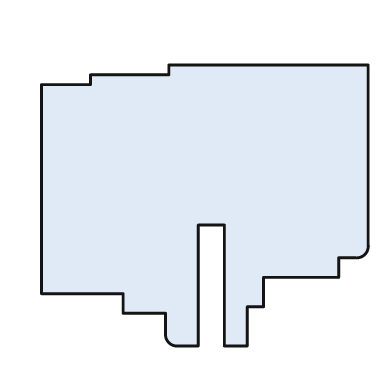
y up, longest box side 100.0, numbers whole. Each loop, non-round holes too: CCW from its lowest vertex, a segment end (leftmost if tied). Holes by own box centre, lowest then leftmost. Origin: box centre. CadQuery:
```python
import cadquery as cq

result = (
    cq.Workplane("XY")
    .moveTo(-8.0, -43.0)
    .lineTo(-2.0, -43.0)
    .lineTo(-2.0, -6.0)
    .lineTo(6.0, -6.0)
    .lineTo(6.0, -43.0)
    .lineTo(13.0, -43.0)
    .lineTo(13.0, -31.0)
    .lineTo(18.0, -31.0)
    .lineTo(18.0, -22.0)
    .lineTo(41.0, -22.0)
    .lineTo(41.0, -16.0)
    .lineTo(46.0, -16.0)
    .threePointArc((49.0, -15.0), (50.0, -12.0))
    .lineTo(50.0, 43.0)
    .lineTo(-11.0, 43.0)
    .lineTo(-11.0, 40.0)
    .lineTo(-35.0, 40.0)
    .lineTo(-35.0, 37.0)
    .lineTo(-50.0, 37.0)
    .lineTo(-50.0, -27.0)
    .lineTo(-25.0, -27.0)
    .lineTo(-25.0, -33.0)
    .lineTo(-12.0, -33.0)
    .lineTo(-12.0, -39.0)
    .threePointArc((-11.0, -42.0), (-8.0, -43.0))
    .close()
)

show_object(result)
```